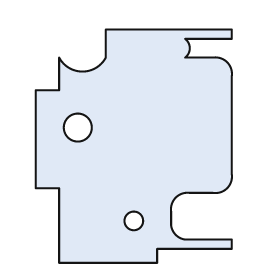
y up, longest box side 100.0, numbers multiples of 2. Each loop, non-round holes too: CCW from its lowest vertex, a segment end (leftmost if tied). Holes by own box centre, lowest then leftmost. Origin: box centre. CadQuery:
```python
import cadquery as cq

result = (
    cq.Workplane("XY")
    .moveTo(-32.0, -50.0)
    .lineTo(10.0, -50.0)
    .lineTo(10.0, -44.0)
    .lineTo(42.0, -44.0)
    .lineTo(42.0, -40.0)
    .lineTo(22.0, -40.0)
    .threePointArc((18.0, -38.0), (16.0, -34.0))
    .lineTo(16.0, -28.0)
    .threePointArc((18.0, -22.0), (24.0, -20.0))
    .lineTo(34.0, -20.0)
    .threePointArc((40.0, -18.0), (42.0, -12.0))
    .lineTo(42.0, 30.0)
    .threePointArc((40.0, 36.0), (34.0, 38.0))
    .lineTo(22.0, 38.0)
    .threePointArc((24.0, 42.0), (22.0, 46.0))
    .lineTo(42.0, 46.0)
    .lineTo(42.0, 50.0)
    .lineTo(-12.0, 50.0)
    .lineTo(-12.0, 38.0)
    .threePointArc((-22.0, 32.0), (-32.0, 38.0))
    .lineTo(-32.0, 24.0)
    .lineTo(-42.0, 24.0)
    .lineTo(-42.0, -18.0)
    .lineTo(-32.0, -18.0)
    .close()
    .moveTo(0.0, -32.0)
    .circle(4.0)
    .moveTo(-24.0, 8.0)
    .circle(6.0)
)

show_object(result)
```